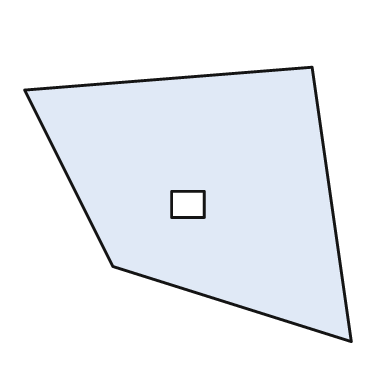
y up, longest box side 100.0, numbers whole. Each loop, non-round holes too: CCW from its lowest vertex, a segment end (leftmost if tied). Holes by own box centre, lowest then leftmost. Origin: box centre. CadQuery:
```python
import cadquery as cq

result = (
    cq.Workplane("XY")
    .moveTo(50.0, -42.0)
    .lineTo(38.0, 42.0)
    .lineTo(-50.0, 35.0)
    .lineTo(-23.0, -19.0)
    .close()
    .moveTo(-5.0, -4.0)
    .lineTo(5.0, -4.0)
    .lineTo(5.0, 4.0)
    .lineTo(-5.0, 4.0)
    .close()
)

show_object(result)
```